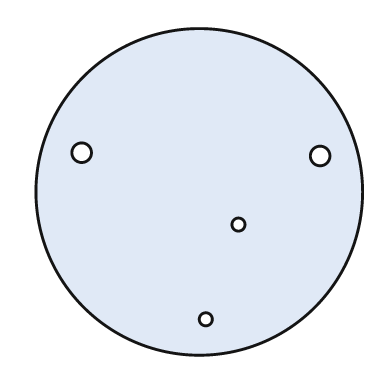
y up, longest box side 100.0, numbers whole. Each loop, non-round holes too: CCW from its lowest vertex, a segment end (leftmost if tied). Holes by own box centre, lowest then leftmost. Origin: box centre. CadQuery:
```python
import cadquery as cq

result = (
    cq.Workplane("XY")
    .moveTo(0.0, 0.0)
    .circle(50.0)
    .moveTo(2.0, -39.0)
    .circle(2.0)
    .moveTo(12.0, -10.0)
    .circle(2.0)
    .moveTo(37.0, 11.0)
    .circle(3.0)
    .moveTo(-36.0, 12.0)
    .circle(3.0)
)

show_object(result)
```